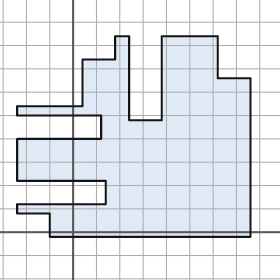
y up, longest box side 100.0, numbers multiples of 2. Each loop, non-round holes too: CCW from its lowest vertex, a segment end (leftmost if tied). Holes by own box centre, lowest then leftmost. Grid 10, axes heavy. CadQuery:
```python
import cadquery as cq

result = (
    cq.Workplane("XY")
    .moveTo(-10.0, -2.0)
    .lineTo(76.0, -2.0)
    .lineTo(76.0, 66.0)
    .lineTo(62.0, 66.0)
    .lineTo(62.0, 84.0)
    .lineTo(38.0, 84.0)
    .lineTo(38.0, 48.0)
    .lineTo(24.0, 48.0)
    .lineTo(24.0, 84.0)
    .lineTo(18.0, 84.0)
    .lineTo(18.0, 74.0)
    .lineTo(4.0, 74.0)
    .lineTo(4.0, 54.0)
    .lineTo(-24.0, 54.0)
    .lineTo(-24.0, 50.0)
    .lineTo(12.0, 50.0)
    .lineTo(12.0, 40.0)
    .lineTo(-24.0, 40.0)
    .lineTo(-24.0, 22.0)
    .lineTo(14.0, 22.0)
    .lineTo(14.0, 12.0)
    .lineTo(-24.0, 12.0)
    .lineTo(-24.0, 8.0)
    .lineTo(-10.0, 8.0)
    .close()
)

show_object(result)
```